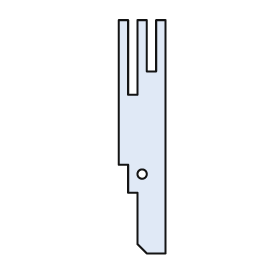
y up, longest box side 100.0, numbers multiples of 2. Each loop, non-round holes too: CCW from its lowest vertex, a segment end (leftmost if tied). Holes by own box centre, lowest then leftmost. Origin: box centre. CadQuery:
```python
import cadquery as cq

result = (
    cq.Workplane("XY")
    .moveTo(2.0, -50.0)
    .lineTo(10.0, -50.0)
    .lineTo(10.0, 50.0)
    .lineTo(6.0, 50.0)
    .lineTo(6.0, 28.0)
    .lineTo(2.0, 28.0)
    .lineTo(2.0, 50.0)
    .lineTo(-2.0, 50.0)
    .lineTo(-2.0, 18.0)
    .lineTo(-6.0, 18.0)
    .lineTo(-6.0, 50.0)
    .lineTo(-10.0, 50.0)
    .lineTo(-10.0, -12.0)
    .lineTo(-6.0, -12.0)
    .lineTo(-6.0, -24.0)
    .lineTo(-2.0, -24.0)
    .lineTo(-2.0, -46.0)
    .close()
    .moveTo(0.0, -16.0)
    .circle(2.0)
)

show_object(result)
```